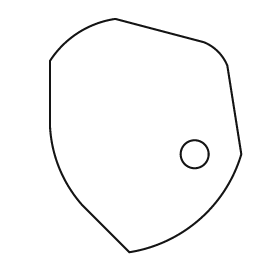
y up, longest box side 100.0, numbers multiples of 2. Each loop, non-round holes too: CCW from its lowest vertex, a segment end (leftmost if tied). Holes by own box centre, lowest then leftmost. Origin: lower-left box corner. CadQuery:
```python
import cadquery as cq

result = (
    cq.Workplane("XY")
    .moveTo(34.0, 0.0)
    .threePointArc((64.0, 14.0), (82.0, 42.0))
    .lineTo(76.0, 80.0)
    .threePointArc((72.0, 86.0), (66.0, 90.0))
    .lineTo(28.0, 100.0)
    .threePointArc((12.0, 94.0), (0.0, 82.0))
    .lineTo(0.0, 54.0)
    .threePointArc((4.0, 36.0), (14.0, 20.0))
    .close()
    .moveTo(62.0, 42.0)
    .circle(6.0)
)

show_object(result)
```